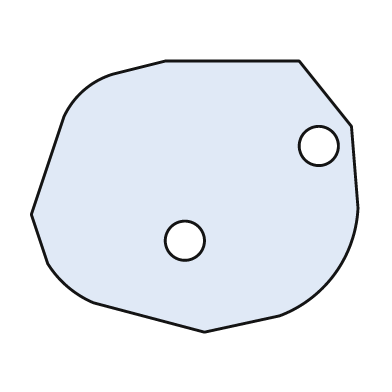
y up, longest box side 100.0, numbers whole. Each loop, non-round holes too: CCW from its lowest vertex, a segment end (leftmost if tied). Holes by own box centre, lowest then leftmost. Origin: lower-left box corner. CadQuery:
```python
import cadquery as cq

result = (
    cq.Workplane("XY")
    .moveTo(53.0, 0.0)
    .lineTo(76.0, 5.0)
    .threePointArc((93.0, 18.0), (100.0, 38.0))
    .lineTo(98.0, 63.0)
    .lineTo(82.0, 83.0)
    .lineTo(41.0, 83.0)
    .lineTo(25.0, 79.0)
    .threePointArc((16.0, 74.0), (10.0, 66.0))
    .lineTo(0.0, 36.0)
    .lineTo(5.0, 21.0)
    .threePointArc((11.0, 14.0), (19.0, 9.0))
    .close()
    .moveTo(47.0, 28.0)
    .circle(6.0)
    .moveTo(88.0, 57.0)
    .circle(6.0)
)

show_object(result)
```